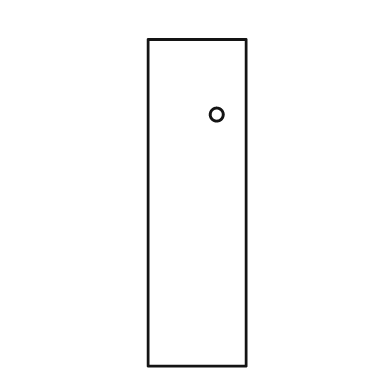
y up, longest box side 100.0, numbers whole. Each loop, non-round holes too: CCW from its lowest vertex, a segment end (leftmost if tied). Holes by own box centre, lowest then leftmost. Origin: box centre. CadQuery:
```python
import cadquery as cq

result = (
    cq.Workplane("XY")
    .moveTo(-15.0, -50.0)
    .lineTo(15.0, -50.0)
    .lineTo(15.0, 50.0)
    .lineTo(-15.0, 50.0)
    .close()
    .moveTo(6.0, 27.0)
    .circle(2.0)
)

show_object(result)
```